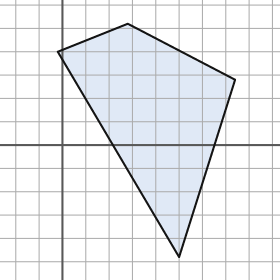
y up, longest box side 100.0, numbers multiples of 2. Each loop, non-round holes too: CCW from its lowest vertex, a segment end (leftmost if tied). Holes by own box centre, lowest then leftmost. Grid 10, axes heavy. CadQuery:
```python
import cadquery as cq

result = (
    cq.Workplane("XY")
    .moveTo(50.0, -48.0)
    .lineTo(74.0, 28.0)
    .lineTo(28.0, 52.0)
    .lineTo(-2.0, 40.0)
    .close()
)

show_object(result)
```